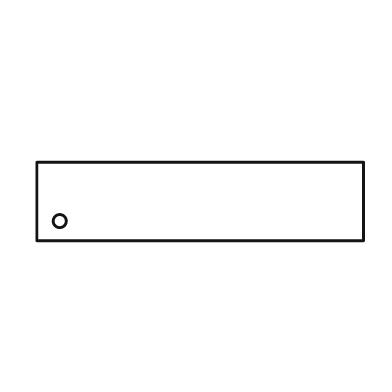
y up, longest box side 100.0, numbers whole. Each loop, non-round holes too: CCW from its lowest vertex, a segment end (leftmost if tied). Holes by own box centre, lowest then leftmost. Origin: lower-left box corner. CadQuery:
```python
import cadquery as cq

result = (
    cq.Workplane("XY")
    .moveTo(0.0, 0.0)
    .lineTo(100.0, 0.0)
    .lineTo(100.0, 24.0)
    .lineTo(0.0, 24.0)
    .close()
    .moveTo(7.0, 6.0)
    .circle(2.0)
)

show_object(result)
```